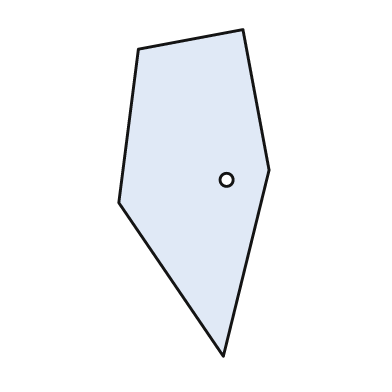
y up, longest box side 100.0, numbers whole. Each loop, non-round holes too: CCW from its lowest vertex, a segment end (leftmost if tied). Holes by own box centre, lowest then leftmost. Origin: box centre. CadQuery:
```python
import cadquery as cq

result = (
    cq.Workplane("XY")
    .moveTo(9.0, -50.0)
    .lineTo(23.0, 7.0)
    .lineTo(15.0, 50.0)
    .lineTo(-17.0, 44.0)
    .lineTo(-23.0, -3.0)
    .close()
    .moveTo(10.0, 4.0)
    .circle(2.0)
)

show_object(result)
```